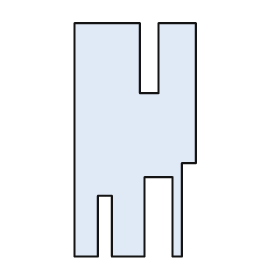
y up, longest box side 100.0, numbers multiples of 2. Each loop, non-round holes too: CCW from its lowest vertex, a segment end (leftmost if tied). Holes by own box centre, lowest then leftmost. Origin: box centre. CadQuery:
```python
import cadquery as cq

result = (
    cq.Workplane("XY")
    .moveTo(-26.0, -50.0)
    .lineTo(-16.0, -50.0)
    .lineTo(-16.0, -24.0)
    .lineTo(-10.0, -24.0)
    .lineTo(-10.0, -50.0)
    .lineTo(4.0, -50.0)
    .lineTo(4.0, -16.0)
    .lineTo(16.0, -16.0)
    .lineTo(16.0, -50.0)
    .lineTo(20.0, -50.0)
    .lineTo(20.0, -10.0)
    .lineTo(26.0, -10.0)
    .lineTo(26.0, 50.0)
    .lineTo(10.0, 50.0)
    .lineTo(10.0, 20.0)
    .lineTo(2.0, 20.0)
    .lineTo(2.0, 50.0)
    .lineTo(-26.0, 50.0)
    .close()
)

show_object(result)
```